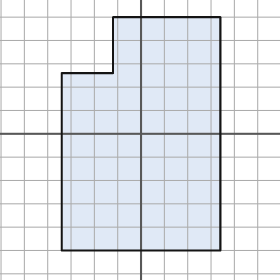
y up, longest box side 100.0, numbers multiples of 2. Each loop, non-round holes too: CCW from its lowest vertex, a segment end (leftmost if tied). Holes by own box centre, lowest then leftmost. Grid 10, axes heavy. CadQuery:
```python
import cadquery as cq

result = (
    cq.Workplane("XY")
    .moveTo(-34.0, -50.0)
    .lineTo(34.0, -50.0)
    .lineTo(34.0, 50.0)
    .lineTo(-12.0, 50.0)
    .lineTo(-12.0, 26.0)
    .lineTo(-34.0, 26.0)
    .close()
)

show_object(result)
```